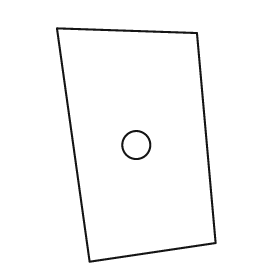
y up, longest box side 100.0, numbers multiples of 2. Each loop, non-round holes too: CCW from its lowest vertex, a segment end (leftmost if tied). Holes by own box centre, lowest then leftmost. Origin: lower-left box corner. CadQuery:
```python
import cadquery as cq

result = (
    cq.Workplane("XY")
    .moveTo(14.0, 0.0)
    .lineTo(68.0, 8.0)
    .lineTo(60.0, 98.0)
    .lineTo(0.0, 100.0)
    .close()
    .moveTo(34.0, 50.0)
    .circle(6.0)
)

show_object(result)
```